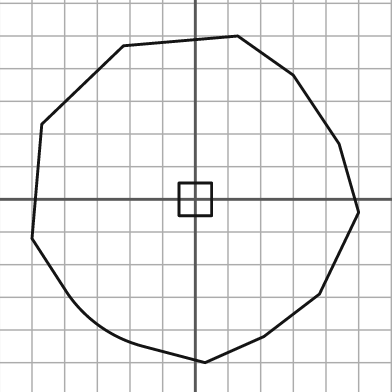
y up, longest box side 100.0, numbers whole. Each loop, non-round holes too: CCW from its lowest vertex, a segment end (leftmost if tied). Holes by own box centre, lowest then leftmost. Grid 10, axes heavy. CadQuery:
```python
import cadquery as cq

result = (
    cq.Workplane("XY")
    .moveTo(3.0, -50.0)
    .lineTo(21.0, -42.0)
    .lineTo(38.0, -29.0)
    .lineTo(50.0, -4.0)
    .lineTo(44.0, 17.0)
    .lineTo(30.0, 38.0)
    .lineTo(13.0, 50.0)
    .lineTo(-22.0, 47.0)
    .lineTo(-47.0, 23.0)
    .lineTo(-50.0, -12.0)
    .lineTo(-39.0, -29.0)
    .threePointArc((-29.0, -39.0), (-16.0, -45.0))
    .close()
    .moveTo(-5.0, -5.0)
    .lineTo(5.0, -5.0)
    .lineTo(5.0, 5.0)
    .lineTo(-5.0, 5.0)
    .close()
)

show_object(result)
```